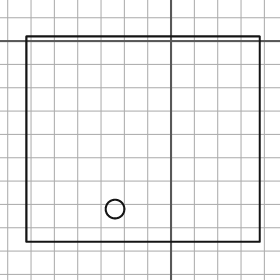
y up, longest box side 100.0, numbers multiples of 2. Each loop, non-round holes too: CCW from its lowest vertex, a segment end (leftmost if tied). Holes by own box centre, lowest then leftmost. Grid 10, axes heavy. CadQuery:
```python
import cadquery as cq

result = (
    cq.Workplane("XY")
    .moveTo(-62.0, -86.0)
    .lineTo(38.0, -86.0)
    .lineTo(38.0, 2.0)
    .lineTo(-62.0, 2.0)
    .close()
    .moveTo(-24.0, -72.0)
    .circle(4.0)
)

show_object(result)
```